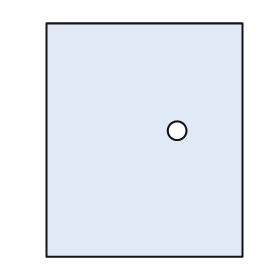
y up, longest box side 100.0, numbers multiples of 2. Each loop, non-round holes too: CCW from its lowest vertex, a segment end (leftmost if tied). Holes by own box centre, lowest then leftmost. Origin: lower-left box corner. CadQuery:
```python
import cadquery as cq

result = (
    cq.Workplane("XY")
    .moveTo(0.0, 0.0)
    .lineTo(84.0, 0.0)
    .lineTo(84.0, 100.0)
    .lineTo(0.0, 100.0)
    .close()
    .moveTo(56.0, 54.0)
    .circle(4.0)
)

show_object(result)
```